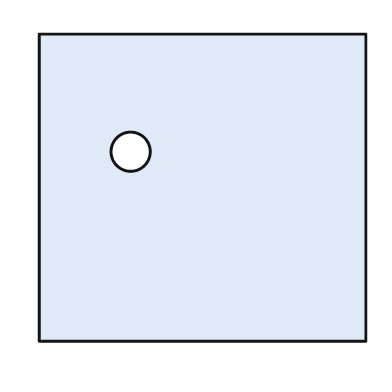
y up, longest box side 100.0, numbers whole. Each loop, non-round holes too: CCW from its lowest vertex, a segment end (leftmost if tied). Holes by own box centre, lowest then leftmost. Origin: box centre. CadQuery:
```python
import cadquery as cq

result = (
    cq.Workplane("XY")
    .moveTo(-50.0, -47.0)
    .lineTo(50.0, -47.0)
    .lineTo(50.0, 47.0)
    .lineTo(-50.0, 47.0)
    .close()
    .moveTo(-22.0, 11.0)
    .circle(6.0)
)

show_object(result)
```